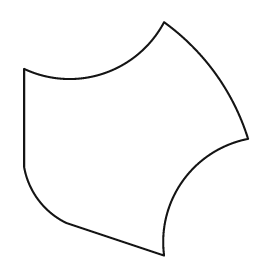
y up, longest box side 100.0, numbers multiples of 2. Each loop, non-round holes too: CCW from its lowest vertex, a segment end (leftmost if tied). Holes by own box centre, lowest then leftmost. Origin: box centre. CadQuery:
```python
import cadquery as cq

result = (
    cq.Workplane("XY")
    .moveTo(12.0, -50.0)
    .threePointArc((20.0, -18.0), (48.0, 0.0))
    .threePointArc((34.0, 28.0), (12.0, 50.0))
    .threePointArc((-14.0, 28.0), (-48.0, 30.0))
    .lineTo(-48.0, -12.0)
    .threePointArc((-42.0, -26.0), (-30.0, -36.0))
    .close()
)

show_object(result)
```